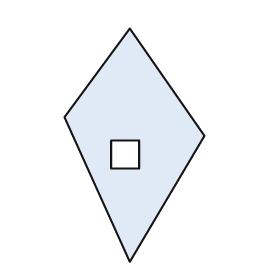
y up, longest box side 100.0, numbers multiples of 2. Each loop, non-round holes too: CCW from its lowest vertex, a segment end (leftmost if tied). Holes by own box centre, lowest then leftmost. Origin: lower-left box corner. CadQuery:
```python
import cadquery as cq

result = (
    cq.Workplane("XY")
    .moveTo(28.0, 0.0)
    .lineTo(60.0, 54.0)
    .lineTo(28.0, 100.0)
    .lineTo(0.0, 62.0)
    .close()
    .moveTo(20.0, 40.0)
    .lineTo(32.0, 40.0)
    .lineTo(32.0, 52.0)
    .lineTo(20.0, 52.0)
    .close()
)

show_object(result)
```